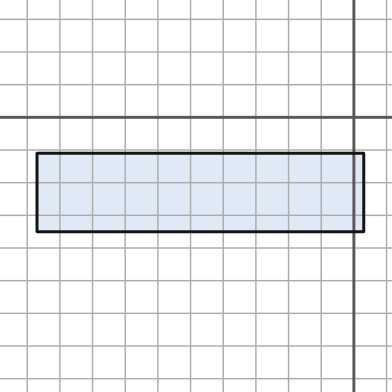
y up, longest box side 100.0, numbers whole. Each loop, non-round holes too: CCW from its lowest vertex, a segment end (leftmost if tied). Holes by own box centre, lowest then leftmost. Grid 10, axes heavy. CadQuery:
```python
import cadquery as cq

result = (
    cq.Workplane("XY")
    .moveTo(-97.0, -35.0)
    .lineTo(3.0, -35.0)
    .lineTo(3.0, -11.0)
    .lineTo(-97.0, -11.0)
    .close()
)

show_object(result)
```